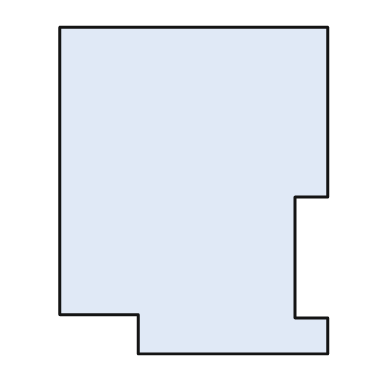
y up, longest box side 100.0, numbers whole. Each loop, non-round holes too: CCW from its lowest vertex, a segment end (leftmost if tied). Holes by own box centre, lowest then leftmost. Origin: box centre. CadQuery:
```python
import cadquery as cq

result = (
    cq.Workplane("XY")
    .moveTo(-17.0, -50.0)
    .lineTo(41.0, -50.0)
    .lineTo(41.0, -39.0)
    .lineTo(31.0, -39.0)
    .lineTo(31.0, -2.0)
    .lineTo(41.0, -2.0)
    .lineTo(41.0, 50.0)
    .lineTo(-41.0, 50.0)
    .lineTo(-41.0, -38.0)
    .lineTo(-17.0, -38.0)
    .close()
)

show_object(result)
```